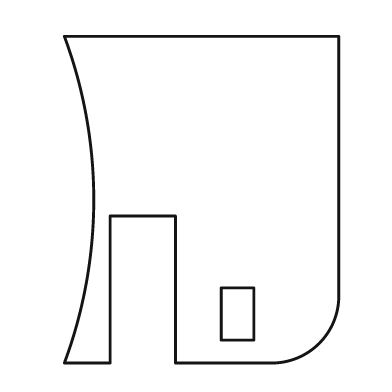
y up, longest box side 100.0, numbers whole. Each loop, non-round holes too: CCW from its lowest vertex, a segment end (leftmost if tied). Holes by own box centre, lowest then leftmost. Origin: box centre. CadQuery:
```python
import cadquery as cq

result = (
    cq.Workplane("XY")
    .moveTo(-42.0, -50.0)
    .lineTo(-28.0, -50.0)
    .lineTo(-28.0, -5.0)
    .lineTo(-8.0, -5.0)
    .lineTo(-8.0, -50.0)
    .lineTo(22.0, -50.0)
    .threePointArc((36.0, -44.0), (42.0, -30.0))
    .lineTo(42.0, 50.0)
    .lineTo(-42.0, 50.0)
    .threePointArc((-33.0, 0.0), (-42.0, -50.0))
    .close()
    .moveTo(6.0, -43.0)
    .lineTo(16.0, -43.0)
    .lineTo(16.0, -27.0)
    .lineTo(6.0, -27.0)
    .close()
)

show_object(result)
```